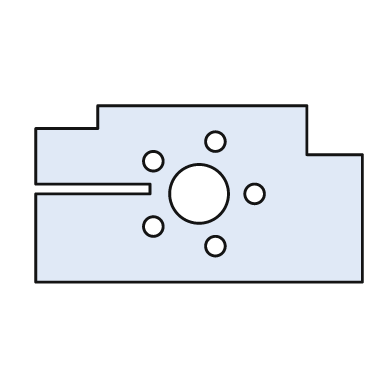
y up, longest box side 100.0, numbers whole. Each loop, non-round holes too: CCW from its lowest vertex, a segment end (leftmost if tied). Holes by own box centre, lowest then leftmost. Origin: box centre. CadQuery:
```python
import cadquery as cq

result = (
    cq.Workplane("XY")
    .moveTo(-50.0, -27.0)
    .lineTo(50.0, -27.0)
    .lineTo(50.0, 12.0)
    .lineTo(33.0, 12.0)
    .lineTo(33.0, 27.0)
    .lineTo(-31.0, 27.0)
    .lineTo(-31.0, 20.0)
    .lineTo(-50.0, 20.0)
    .lineTo(-50.0, 3.0)
    .lineTo(-15.0, 3.0)
    .lineTo(-15.0, 0.0)
    .lineTo(-50.0, 0.0)
    .close()
    .moveTo(5.0, -16.0)
    .circle(3.0)
    .moveTo(-14.0, -10.0)
    .circle(3.0)
    .moveTo(0.0, 0.0)
    .circle(9.0)
    .moveTo(17.0, 0.0)
    .circle(3.0)
    .moveTo(-14.0, 10.0)
    .circle(3.0)
    .moveTo(5.0, 16.0)
    .circle(3.0)
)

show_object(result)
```